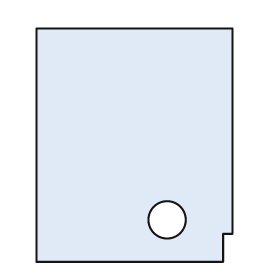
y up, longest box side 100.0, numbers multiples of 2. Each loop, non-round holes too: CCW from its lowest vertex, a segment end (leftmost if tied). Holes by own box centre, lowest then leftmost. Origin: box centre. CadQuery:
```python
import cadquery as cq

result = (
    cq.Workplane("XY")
    .moveTo(-42.0, -50.0)
    .lineTo(38.0, -50.0)
    .lineTo(38.0, -38.0)
    .lineTo(42.0, -38.0)
    .lineTo(42.0, 50.0)
    .lineTo(-42.0, 50.0)
    .close()
    .moveTo(14.0, -32.0)
    .circle(8.0)
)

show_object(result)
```